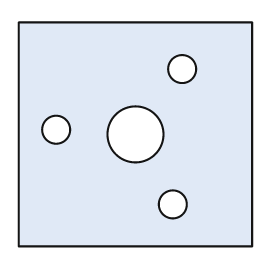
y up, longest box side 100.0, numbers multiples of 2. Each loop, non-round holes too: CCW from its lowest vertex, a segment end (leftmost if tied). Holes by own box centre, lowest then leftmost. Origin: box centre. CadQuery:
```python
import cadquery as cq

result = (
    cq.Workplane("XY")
    .moveTo(-50.0, -48.0)
    .lineTo(50.0, -48.0)
    .lineTo(50.0, 48.0)
    .lineTo(-50.0, 48.0)
    .close()
    .moveTo(16.0, -30.0)
    .circle(6.0)
    .moveTo(0.0, 0.0)
    .circle(12.0)
    .moveTo(-34.0, 2.0)
    .circle(6.0)
    .moveTo(20.0, 28.0)
    .circle(6.0)
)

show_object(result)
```